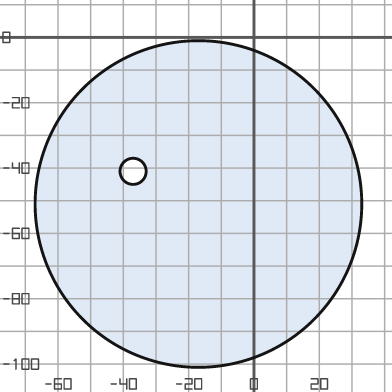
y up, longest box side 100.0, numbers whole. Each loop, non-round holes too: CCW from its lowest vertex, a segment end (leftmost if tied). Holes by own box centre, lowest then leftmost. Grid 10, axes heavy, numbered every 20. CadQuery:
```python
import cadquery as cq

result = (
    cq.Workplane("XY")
    .moveTo(-17.0, -51.0)
    .circle(50.0)
    .moveTo(-37.0, -41.0)
    .circle(4.0)
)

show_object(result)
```